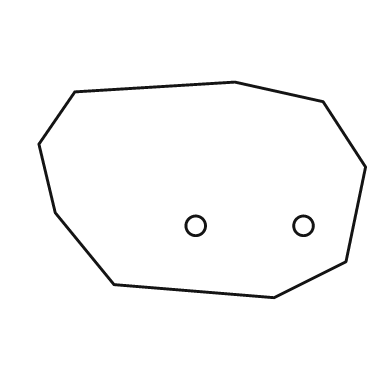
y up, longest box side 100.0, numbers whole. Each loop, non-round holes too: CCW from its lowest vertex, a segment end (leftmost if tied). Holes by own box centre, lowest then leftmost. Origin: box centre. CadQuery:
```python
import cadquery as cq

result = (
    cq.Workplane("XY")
    .moveTo(22.0, -33.0)
    .lineTo(44.0, -22.0)
    .lineTo(50.0, 7.0)
    .lineTo(37.0, 27.0)
    .lineTo(10.0, 33.0)
    .lineTo(-39.0, 30.0)
    .lineTo(-50.0, 14.0)
    .lineTo(-45.0, -7.0)
    .lineTo(-27.0, -29.0)
    .close()
    .moveTo(-2.0, -11.0)
    .circle(3.0)
    .moveTo(31.0, -11.0)
    .circle(3.0)
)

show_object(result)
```